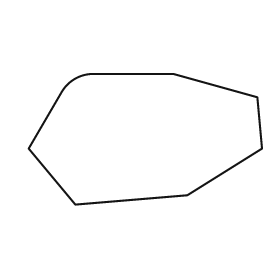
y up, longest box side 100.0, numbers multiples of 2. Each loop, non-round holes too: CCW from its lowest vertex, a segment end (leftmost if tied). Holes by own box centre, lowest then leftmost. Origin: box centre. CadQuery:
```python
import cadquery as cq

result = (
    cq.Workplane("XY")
    .moveTo(-30.0, -28.0)
    .lineTo(18.0, -24.0)
    .lineTo(50.0, -4.0)
    .lineTo(48.0, 18.0)
    .lineTo(12.0, 28.0)
    .lineTo(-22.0, 28.0)
    .threePointArc((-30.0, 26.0), (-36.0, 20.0))
    .lineTo(-50.0, -4.0)
    .close()
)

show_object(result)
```